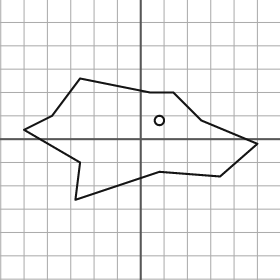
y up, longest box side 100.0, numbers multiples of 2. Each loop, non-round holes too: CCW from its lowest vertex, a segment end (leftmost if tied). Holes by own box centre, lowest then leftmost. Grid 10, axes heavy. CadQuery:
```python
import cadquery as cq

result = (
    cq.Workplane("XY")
    .moveTo(-28.0, -26.0)
    .lineTo(8.0, -14.0)
    .lineTo(34.0, -16.0)
    .lineTo(50.0, -2.0)
    .lineTo(26.0, 8.0)
    .lineTo(14.0, 20.0)
    .lineTo(4.0, 20.0)
    .lineTo(-26.0, 26.0)
    .lineTo(-38.0, 10.0)
    .lineTo(-50.0, 4.0)
    .lineTo(-26.0, -10.0)
    .close()
    .moveTo(8.0, 8.0)
    .circle(2.0)
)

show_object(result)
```